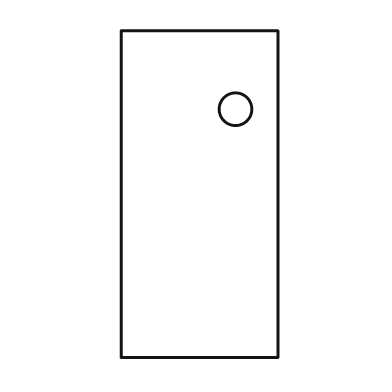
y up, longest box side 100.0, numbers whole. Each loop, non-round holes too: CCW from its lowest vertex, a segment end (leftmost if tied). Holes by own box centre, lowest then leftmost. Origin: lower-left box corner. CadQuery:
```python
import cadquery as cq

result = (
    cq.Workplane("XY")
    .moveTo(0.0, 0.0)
    .lineTo(48.0, 0.0)
    .lineTo(48.0, 100.0)
    .lineTo(0.0, 100.0)
    .close()
    .moveTo(35.0, 76.0)
    .circle(5.0)
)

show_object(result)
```